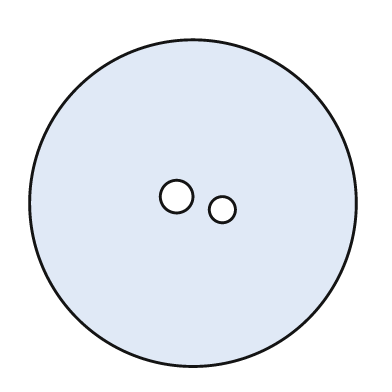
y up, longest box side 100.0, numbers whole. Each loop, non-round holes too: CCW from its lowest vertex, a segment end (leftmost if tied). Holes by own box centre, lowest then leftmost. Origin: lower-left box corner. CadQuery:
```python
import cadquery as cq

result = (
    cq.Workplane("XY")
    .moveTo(50.0, 50.0)
    .circle(50.0)
    .moveTo(59.0, 48.0)
    .circle(4.0)
    .moveTo(45.0, 52.0)
    .circle(5.0)
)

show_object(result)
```